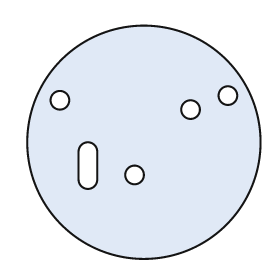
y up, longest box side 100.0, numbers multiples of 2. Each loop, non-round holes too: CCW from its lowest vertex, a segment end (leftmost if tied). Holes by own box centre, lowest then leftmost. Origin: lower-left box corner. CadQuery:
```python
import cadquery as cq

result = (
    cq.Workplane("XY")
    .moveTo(50.0, 50.0)
    .circle(50.0)
    .moveTo(46.0, 36.0)
    .circle(4.0)
    .moveTo(22.0, 34.0)
    .threePointArc((26.0, 30.0), (30.0, 34.0))
    .lineTo(30.0, 46.0)
    .threePointArc((26.0, 50.0), (22.0, 46.0))
    .close()
    .moveTo(70.0, 64.0)
    .circle(4.0)
    .moveTo(14.0, 68.0)
    .circle(4.0)
    .moveTo(86.0, 70.0)
    .circle(4.0)
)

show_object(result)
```